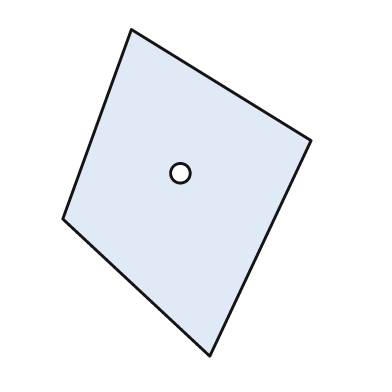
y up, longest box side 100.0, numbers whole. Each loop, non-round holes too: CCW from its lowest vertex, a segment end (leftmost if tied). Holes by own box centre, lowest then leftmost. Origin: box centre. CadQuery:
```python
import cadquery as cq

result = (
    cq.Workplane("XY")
    .moveTo(7.0, -50.0)
    .lineTo(38.0, 16.0)
    .lineTo(-17.0, 50.0)
    .lineTo(-38.0, -8.0)
    .close()
    .moveTo(-2.0, 6.0)
    .circle(3.0)
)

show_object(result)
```